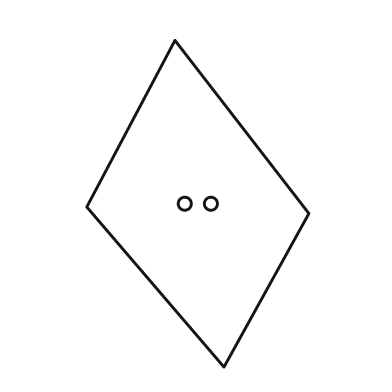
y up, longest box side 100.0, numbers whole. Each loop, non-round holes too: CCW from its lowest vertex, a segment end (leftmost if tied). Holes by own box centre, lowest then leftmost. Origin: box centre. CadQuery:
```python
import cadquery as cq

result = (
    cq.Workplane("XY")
    .moveTo(8.0, -50.0)
    .lineTo(34.0, -3.0)
    .lineTo(-7.0, 50.0)
    .lineTo(-34.0, -1.0)
    .close()
    .moveTo(-4.0, 0.0)
    .circle(2.0)
    .moveTo(4.0, 0.0)
    .circle(2.0)
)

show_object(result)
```